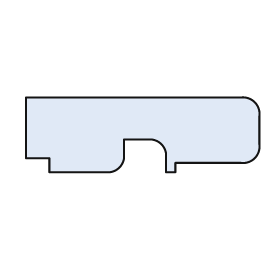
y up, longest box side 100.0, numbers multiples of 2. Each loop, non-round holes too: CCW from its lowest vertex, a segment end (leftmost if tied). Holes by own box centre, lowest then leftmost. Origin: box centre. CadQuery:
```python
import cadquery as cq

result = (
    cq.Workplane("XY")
    .moveTo(-40.0, -16.0)
    .lineTo(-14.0, -16.0)
    .threePointArc((-10.0, -14.0), (-8.0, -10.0))
    .lineTo(-8.0, -2.0)
    .lineTo(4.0, -2.0)
    .threePointArc((8.0, -4.0), (10.0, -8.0))
    .lineTo(10.0, -16.0)
    .lineTo(14.0, -16.0)
    .lineTo(14.0, -12.0)
    .lineTo(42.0, -12.0)
    .threePointArc((48.0, -10.0), (50.0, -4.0))
    .lineTo(50.0, 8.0)
    .threePointArc((48.0, 14.0), (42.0, 16.0))
    .lineTo(-50.0, 16.0)
    .lineTo(-50.0, -10.0)
    .lineTo(-40.0, -10.0)
    .close()
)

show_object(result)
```